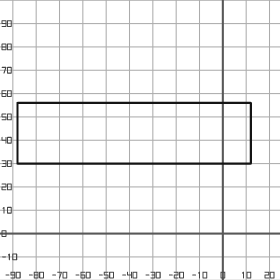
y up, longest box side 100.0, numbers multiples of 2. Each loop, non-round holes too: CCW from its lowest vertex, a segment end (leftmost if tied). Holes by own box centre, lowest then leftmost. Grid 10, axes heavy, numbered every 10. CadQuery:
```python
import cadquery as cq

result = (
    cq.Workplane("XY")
    .moveTo(-88.0, 30.0)
    .lineTo(12.0, 30.0)
    .lineTo(12.0, 56.0)
    .lineTo(-88.0, 56.0)
    .close()
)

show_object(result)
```